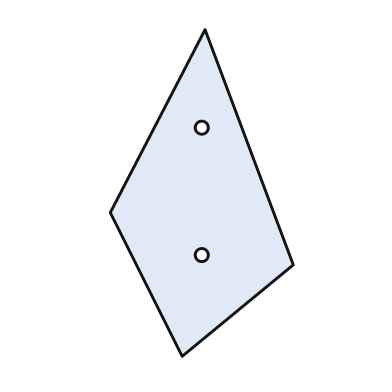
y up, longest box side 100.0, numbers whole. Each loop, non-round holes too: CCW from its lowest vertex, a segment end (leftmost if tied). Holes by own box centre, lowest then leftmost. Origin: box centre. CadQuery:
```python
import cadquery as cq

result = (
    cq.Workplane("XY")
    .moveTo(-6.0, -50.0)
    .lineTo(28.0, -22.0)
    .lineTo(1.0, 50.0)
    .lineTo(-28.0, -6.0)
    .close()
    .moveTo(0.0, -19.0)
    .circle(2.0)
    .moveTo(0.0, 20.0)
    .circle(2.0)
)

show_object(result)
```